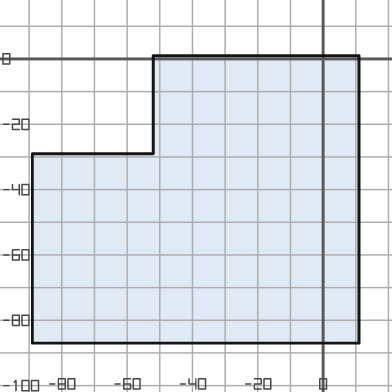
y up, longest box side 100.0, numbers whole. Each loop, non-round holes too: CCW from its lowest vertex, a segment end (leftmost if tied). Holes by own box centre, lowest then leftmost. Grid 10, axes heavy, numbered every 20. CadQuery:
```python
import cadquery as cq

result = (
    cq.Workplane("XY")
    .moveTo(-89.0, -87.0)
    .lineTo(11.0, -87.0)
    .lineTo(11.0, 1.0)
    .lineTo(-52.0, 1.0)
    .lineTo(-52.0, -29.0)
    .lineTo(-89.0, -29.0)
    .close()
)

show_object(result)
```